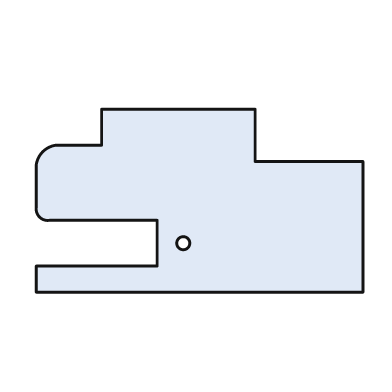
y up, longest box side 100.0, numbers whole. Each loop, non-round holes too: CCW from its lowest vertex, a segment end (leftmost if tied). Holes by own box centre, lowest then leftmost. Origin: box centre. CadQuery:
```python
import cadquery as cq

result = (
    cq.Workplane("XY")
    .moveTo(-50.0, -28.0)
    .lineTo(50.0, -28.0)
    .lineTo(50.0, 12.0)
    .lineTo(17.0, 12.0)
    .lineTo(17.0, 28.0)
    .lineTo(-30.0, 28.0)
    .lineTo(-30.0, 17.0)
    .lineTo(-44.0, 17.0)
    .threePointArc((-48.0, 15.0), (-50.0, 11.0))
    .lineTo(-50.0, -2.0)
    .threePointArc((-49.0, -5.0), (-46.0, -6.0))
    .lineTo(-13.0, -6.0)
    .lineTo(-13.0, -20.0)
    .lineTo(-50.0, -20.0)
    .close()
    .moveTo(-5.0, -13.0)
    .circle(2.0)
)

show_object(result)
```